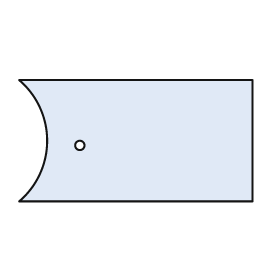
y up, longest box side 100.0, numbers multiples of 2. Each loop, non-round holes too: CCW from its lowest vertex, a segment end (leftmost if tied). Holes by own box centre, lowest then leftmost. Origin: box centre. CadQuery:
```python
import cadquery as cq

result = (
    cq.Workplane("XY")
    .moveTo(-50.0, -26.0)
    .lineTo(50.0, -26.0)
    .lineTo(50.0, 26.0)
    .lineTo(-50.0, 26.0)
    .threePointArc((-38.0, 0.0), (-50.0, -26.0))
    .close()
    .moveTo(-24.0, -2.0)
    .circle(2.0)
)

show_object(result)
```